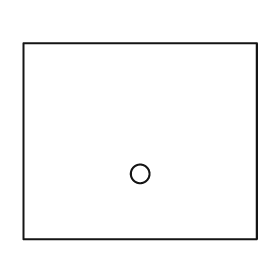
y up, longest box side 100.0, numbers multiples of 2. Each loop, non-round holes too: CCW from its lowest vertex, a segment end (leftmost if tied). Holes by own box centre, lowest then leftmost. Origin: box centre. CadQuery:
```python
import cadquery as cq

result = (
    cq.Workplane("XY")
    .moveTo(-50.0, -42.0)
    .lineTo(50.0, -42.0)
    .lineTo(50.0, 42.0)
    .lineTo(-50.0, 42.0)
    .close()
    .moveTo(0.0, -14.0)
    .circle(4.0)
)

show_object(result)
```